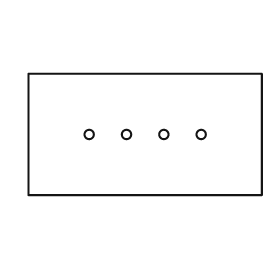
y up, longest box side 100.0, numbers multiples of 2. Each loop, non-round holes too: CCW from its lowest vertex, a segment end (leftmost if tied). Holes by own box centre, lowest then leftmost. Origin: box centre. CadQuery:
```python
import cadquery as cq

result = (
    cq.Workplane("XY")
    .moveTo(-50.0, -26.0)
    .lineTo(50.0, -26.0)
    .lineTo(50.0, 26.0)
    .lineTo(-50.0, 26.0)
    .close()
    .moveTo(-24.0, 0.0)
    .circle(2.0)
    .moveTo(-8.0, 0.0)
    .circle(2.0)
    .moveTo(8.0, 0.0)
    .circle(2.0)
    .moveTo(24.0, 0.0)
    .circle(2.0)
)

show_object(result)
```